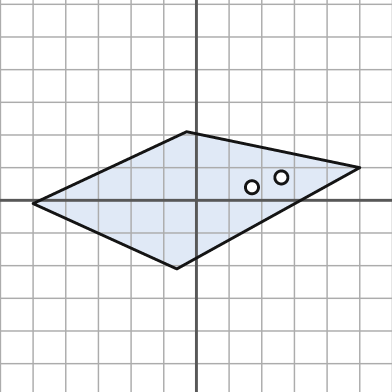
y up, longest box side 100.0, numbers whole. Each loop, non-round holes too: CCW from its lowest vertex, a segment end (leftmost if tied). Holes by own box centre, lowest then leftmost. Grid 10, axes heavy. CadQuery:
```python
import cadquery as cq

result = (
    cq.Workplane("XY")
    .moveTo(-6.0, -21.0)
    .lineTo(50.0, 10.0)
    .lineTo(-3.0, 21.0)
    .lineTo(-50.0, -1.0)
    .close()
    .moveTo(17.0, 4.0)
    .circle(2.0)
    .moveTo(26.0, 7.0)
    .circle(2.0)
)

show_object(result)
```